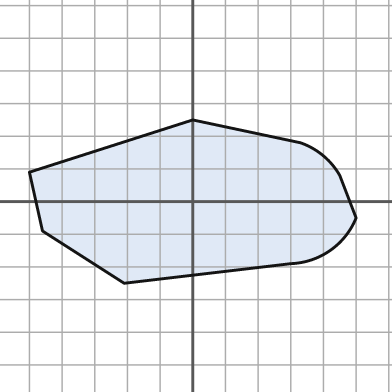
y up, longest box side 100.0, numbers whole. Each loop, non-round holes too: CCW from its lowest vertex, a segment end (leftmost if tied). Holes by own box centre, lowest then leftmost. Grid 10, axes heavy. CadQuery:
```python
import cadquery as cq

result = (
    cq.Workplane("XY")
    .moveTo(-21.0, -25.0)
    .lineTo(30.0, -19.0)
    .threePointArc((42.0, -15.0), (50.0, -5.0))
    .lineTo(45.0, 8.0)
    .threePointArc((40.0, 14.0), (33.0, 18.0))
    .lineTo(0.0, 25.0)
    .lineTo(-50.0, 9.0)
    .lineTo(-46.0, -9.0)
    .close()
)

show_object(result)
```